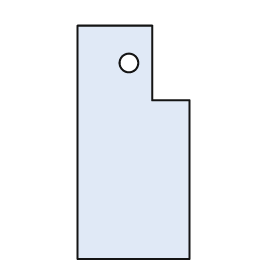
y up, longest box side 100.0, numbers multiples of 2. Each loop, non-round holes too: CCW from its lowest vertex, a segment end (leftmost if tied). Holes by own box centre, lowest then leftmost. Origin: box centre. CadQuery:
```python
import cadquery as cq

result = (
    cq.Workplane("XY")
    .moveTo(-24.0, -50.0)
    .lineTo(24.0, -50.0)
    .lineTo(24.0, 18.0)
    .lineTo(8.0, 18.0)
    .lineTo(8.0, 50.0)
    .lineTo(-24.0, 50.0)
    .close()
    .moveTo(-2.0, 34.0)
    .circle(4.0)
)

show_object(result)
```